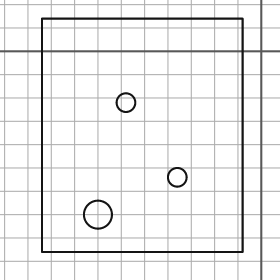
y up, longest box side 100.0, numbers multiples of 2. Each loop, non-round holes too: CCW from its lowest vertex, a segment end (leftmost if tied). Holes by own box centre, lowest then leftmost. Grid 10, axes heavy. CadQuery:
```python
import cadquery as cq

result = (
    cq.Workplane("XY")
    .moveTo(-94.0, -86.0)
    .lineTo(-8.0, -86.0)
    .lineTo(-8.0, 14.0)
    .lineTo(-94.0, 14.0)
    .close()
    .moveTo(-70.0, -70.0)
    .circle(6.0)
    .moveTo(-36.0, -54.0)
    .circle(4.0)
    .moveTo(-58.0, -22.0)
    .circle(4.0)
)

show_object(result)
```